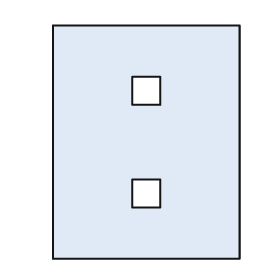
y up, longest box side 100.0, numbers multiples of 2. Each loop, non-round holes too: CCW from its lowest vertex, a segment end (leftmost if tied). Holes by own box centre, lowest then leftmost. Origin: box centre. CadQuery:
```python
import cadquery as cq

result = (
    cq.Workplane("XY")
    .moveTo(-40.0, -50.0)
    .lineTo(40.0, -50.0)
    .lineTo(40.0, 50.0)
    .lineTo(-40.0, 50.0)
    .close()
    .moveTo(-6.0, -28.0)
    .lineTo(6.0, -28.0)
    .lineTo(6.0, -16.0)
    .lineTo(-6.0, -16.0)
    .close()
    .moveTo(-6.0, 16.0)
    .lineTo(6.0, 16.0)
    .lineTo(6.0, 28.0)
    .lineTo(-6.0, 28.0)
    .close()
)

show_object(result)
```